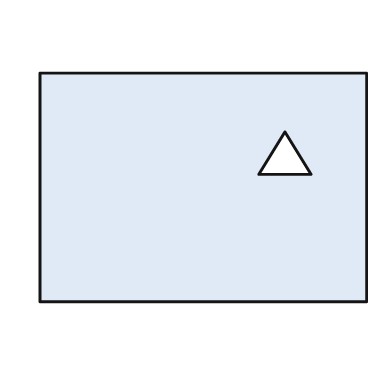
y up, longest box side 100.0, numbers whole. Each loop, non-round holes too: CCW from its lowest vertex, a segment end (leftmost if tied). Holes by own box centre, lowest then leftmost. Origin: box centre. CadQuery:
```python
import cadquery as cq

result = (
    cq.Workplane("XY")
    .moveTo(-50.0, -35.0)
    .lineTo(50.0, -35.0)
    .lineTo(50.0, 35.0)
    .lineTo(-50.0, 35.0)
    .close()
    .moveTo(17.0, 4.0)
    .lineTo(33.0, 4.0)
    .lineTo(25.0, 17.0)
    .close()
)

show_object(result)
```